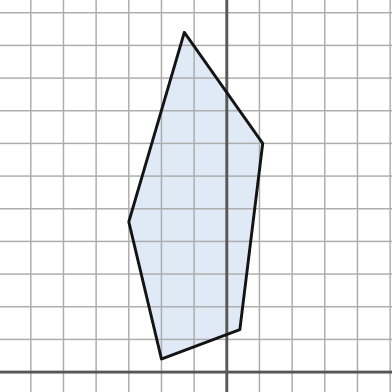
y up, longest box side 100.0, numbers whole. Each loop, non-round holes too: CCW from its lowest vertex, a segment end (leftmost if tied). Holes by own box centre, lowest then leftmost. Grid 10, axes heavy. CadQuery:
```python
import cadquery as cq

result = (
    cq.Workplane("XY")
    .moveTo(-20.0, 4.0)
    .lineTo(4.0, 13.0)
    .lineTo(11.0, 70.0)
    .lineTo(-13.0, 104.0)
    .lineTo(-30.0, 46.0)
    .close()
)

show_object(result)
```